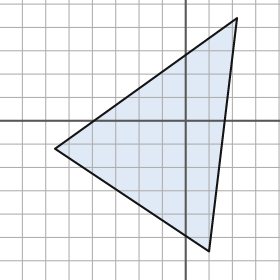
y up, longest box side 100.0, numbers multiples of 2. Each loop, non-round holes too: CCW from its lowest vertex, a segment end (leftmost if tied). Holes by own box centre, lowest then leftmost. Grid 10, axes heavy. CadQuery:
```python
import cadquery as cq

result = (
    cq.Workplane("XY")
    .moveTo(10.0, -56.0)
    .lineTo(22.0, 44.0)
    .lineTo(-56.0, -12.0)
    .close()
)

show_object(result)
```